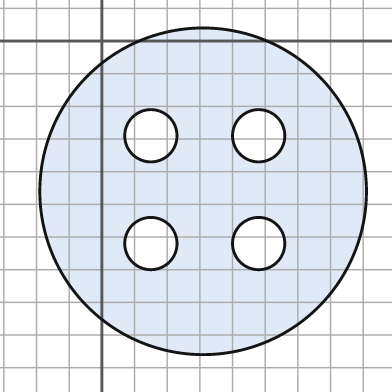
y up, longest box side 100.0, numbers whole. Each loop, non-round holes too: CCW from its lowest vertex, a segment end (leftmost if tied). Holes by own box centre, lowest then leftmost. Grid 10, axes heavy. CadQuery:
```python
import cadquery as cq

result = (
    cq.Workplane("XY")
    .moveTo(31.0, -46.0)
    .circle(50.0)
    .moveTo(15.0, -62.0)
    .circle(8.0)
    .moveTo(48.0, -62.0)
    .circle(8.0)
    .moveTo(15.0, -29.0)
    .circle(8.0)
    .moveTo(48.0, -29.0)
    .circle(8.0)
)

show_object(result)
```